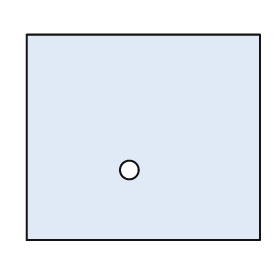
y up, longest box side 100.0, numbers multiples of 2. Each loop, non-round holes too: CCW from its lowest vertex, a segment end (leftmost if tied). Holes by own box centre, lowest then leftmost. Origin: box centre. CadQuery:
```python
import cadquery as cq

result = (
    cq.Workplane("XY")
    .moveTo(-50.0, -44.0)
    .lineTo(50.0, -44.0)
    .lineTo(50.0, 44.0)
    .lineTo(-50.0, 44.0)
    .close()
    .moveTo(-6.0, -14.0)
    .circle(4.0)
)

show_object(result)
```